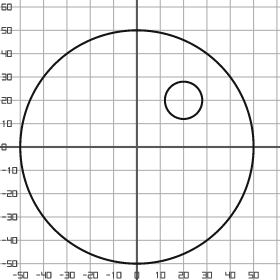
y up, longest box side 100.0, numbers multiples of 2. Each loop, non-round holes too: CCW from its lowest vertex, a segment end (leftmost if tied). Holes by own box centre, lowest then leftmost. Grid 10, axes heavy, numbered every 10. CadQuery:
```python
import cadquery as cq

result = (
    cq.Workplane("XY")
    .moveTo(0.0, 0.0)
    .circle(50.0)
    .moveTo(20.0, 20.0)
    .circle(8.0)
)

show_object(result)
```